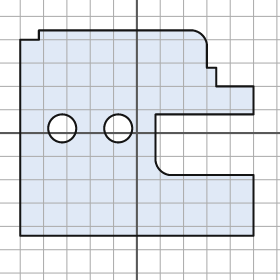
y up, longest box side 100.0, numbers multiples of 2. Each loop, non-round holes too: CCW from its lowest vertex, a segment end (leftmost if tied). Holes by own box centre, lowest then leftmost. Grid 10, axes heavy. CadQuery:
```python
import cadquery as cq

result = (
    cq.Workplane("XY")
    .moveTo(-50.0, -44.0)
    .lineTo(50.0, -44.0)
    .lineTo(50.0, -18.0)
    .lineTo(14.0, -18.0)
    .threePointArc((10.0, -16.0), (8.0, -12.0))
    .lineTo(8.0, 8.0)
    .lineTo(50.0, 8.0)
    .lineTo(50.0, 20.0)
    .lineTo(34.0, 20.0)
    .lineTo(34.0, 28.0)
    .lineTo(30.0, 28.0)
    .lineTo(30.0, 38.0)
    .threePointArc((28.0, 42.0), (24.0, 44.0))
    .lineTo(-42.0, 44.0)
    .lineTo(-42.0, 40.0)
    .lineTo(-50.0, 40.0)
    .close()
    .moveTo(-32.0, 2.0)
    .circle(6.0)
    .moveTo(-8.0, 2.0)
    .circle(6.0)
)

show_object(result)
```